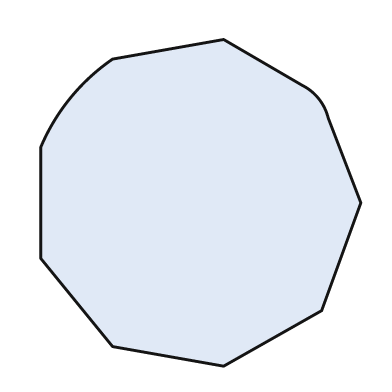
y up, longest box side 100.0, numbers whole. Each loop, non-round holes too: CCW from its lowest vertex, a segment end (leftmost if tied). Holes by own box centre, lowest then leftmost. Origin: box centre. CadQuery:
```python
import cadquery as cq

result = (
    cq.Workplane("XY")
    .moveTo(7.0, -50.0)
    .lineTo(37.0, -33.0)
    .lineTo(49.0, 0.0)
    .lineTo(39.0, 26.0)
    .threePointArc((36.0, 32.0), (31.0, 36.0))
    .lineTo(7.0, 50.0)
    .lineTo(-27.0, 44.0)
    .threePointArc((-40.0, 32.0), (-49.0, 17.0))
    .lineTo(-49.0, -17.0)
    .lineTo(-27.0, -44.0)
    .close()
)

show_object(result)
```